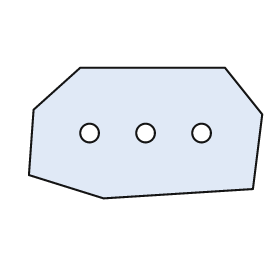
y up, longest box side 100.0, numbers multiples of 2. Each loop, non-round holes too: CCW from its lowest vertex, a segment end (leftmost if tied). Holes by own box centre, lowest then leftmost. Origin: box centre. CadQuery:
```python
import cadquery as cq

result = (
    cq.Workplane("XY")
    .moveTo(-18.0, -28.0)
    .lineTo(46.0, -24.0)
    .lineTo(50.0, 8.0)
    .lineTo(34.0, 28.0)
    .lineTo(-28.0, 28.0)
    .lineTo(-48.0, 10.0)
    .lineTo(-50.0, -18.0)
    .close()
    .moveTo(-24.0, 0.0)
    .circle(4.0)
    .moveTo(0.0, 0.0)
    .circle(4.0)
    .moveTo(24.0, 0.0)
    .circle(4.0)
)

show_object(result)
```